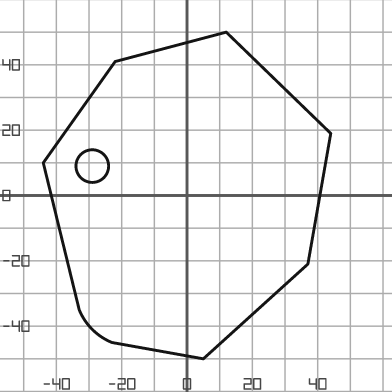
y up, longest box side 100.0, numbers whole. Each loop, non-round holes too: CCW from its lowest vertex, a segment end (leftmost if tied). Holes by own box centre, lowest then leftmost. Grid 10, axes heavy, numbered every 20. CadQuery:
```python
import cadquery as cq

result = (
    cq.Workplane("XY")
    .moveTo(5.0, -50.0)
    .lineTo(37.0, -21.0)
    .lineTo(44.0, 19.0)
    .lineTo(12.0, 50.0)
    .lineTo(-22.0, 41.0)
    .lineTo(-44.0, 10.0)
    .lineTo(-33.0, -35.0)
    .threePointArc((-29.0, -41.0), (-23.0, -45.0))
    .close()
    .moveTo(-29.0, 9.0)
    .circle(5.0)
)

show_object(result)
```